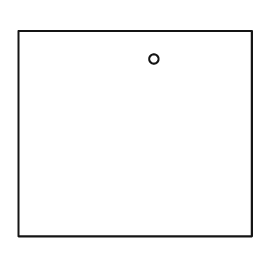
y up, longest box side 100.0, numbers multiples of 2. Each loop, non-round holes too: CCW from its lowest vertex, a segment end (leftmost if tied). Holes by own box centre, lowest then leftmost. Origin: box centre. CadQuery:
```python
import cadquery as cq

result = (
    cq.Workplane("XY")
    .moveTo(-50.0, -44.0)
    .lineTo(50.0, -44.0)
    .lineTo(50.0, 44.0)
    .lineTo(-50.0, 44.0)
    .close()
    .moveTo(8.0, 32.0)
    .circle(2.0)
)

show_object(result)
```